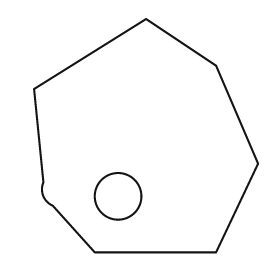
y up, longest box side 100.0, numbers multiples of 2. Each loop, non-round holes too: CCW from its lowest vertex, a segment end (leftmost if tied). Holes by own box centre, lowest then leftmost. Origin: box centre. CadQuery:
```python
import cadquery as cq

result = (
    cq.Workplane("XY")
    .moveTo(-22.0, -50.0)
    .lineTo(30.0, -50.0)
    .lineTo(48.0, -12.0)
    .lineTo(30.0, 30.0)
    .lineTo(0.0, 50.0)
    .lineTo(-48.0, 20.0)
    .lineTo(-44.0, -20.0)
    .threePointArc((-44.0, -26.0), (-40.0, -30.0))
    .close()
    .moveTo(-12.0, -26.0)
    .circle(10.0)
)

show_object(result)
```